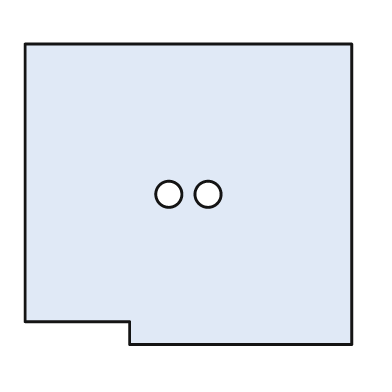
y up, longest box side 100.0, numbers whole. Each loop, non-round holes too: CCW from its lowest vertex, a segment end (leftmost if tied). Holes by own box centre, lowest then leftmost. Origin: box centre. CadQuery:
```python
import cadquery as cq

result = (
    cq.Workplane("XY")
    .moveTo(-18.0, -46.0)
    .lineTo(50.0, -46.0)
    .lineTo(50.0, 46.0)
    .lineTo(-50.0, 46.0)
    .lineTo(-50.0, -39.0)
    .lineTo(-18.0, -39.0)
    .close()
    .moveTo(-6.0, 0.0)
    .circle(4.0)
    .moveTo(6.0, 0.0)
    .circle(4.0)
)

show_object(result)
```